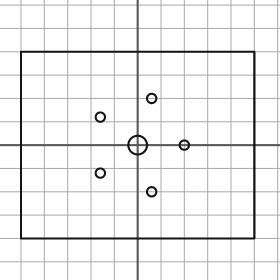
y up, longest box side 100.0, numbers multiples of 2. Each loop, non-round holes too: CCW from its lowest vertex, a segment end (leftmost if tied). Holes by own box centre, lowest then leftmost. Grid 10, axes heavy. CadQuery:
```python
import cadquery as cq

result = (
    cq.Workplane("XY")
    .moveTo(-50.0, -40.0)
    .lineTo(50.0, -40.0)
    .lineTo(50.0, 40.0)
    .lineTo(-50.0, 40.0)
    .close()
    .moveTo(6.0, -20.0)
    .circle(2.0)
    .moveTo(-16.0, -12.0)
    .circle(2.0)
    .moveTo(0.0, 0.0)
    .circle(4.0)
    .moveTo(20.0, 0.0)
    .circle(2.0)
    .moveTo(-16.0, 12.0)
    .circle(2.0)
    .moveTo(6.0, 20.0)
    .circle(2.0)
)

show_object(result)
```